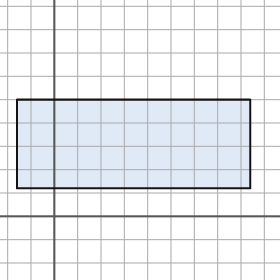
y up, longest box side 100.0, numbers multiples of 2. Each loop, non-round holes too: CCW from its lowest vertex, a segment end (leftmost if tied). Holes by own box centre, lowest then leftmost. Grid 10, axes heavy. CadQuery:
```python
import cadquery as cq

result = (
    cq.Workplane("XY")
    .moveTo(-16.0, 12.0)
    .lineTo(84.0, 12.0)
    .lineTo(84.0, 50.0)
    .lineTo(-16.0, 50.0)
    .close()
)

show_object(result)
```